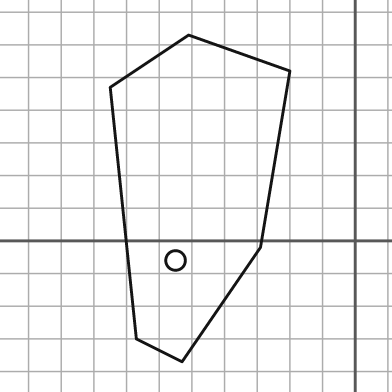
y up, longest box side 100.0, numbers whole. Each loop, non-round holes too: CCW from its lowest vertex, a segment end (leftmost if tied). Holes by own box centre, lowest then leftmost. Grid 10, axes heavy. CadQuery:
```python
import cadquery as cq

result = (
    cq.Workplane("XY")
    .moveTo(-53.0, -37.0)
    .lineTo(-29.0, -2.0)
    .lineTo(-20.0, 52.0)
    .lineTo(-51.0, 63.0)
    .lineTo(-75.0, 47.0)
    .lineTo(-67.0, -30.0)
    .close()
    .moveTo(-55.0, -6.0)
    .circle(3.0)
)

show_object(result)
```